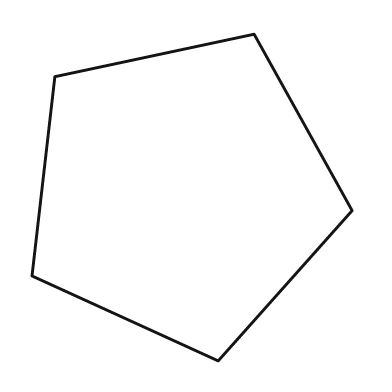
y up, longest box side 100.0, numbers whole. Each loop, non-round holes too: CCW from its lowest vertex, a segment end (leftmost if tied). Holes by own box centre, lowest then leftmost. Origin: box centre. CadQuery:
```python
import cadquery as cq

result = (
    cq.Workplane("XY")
    .moveTo(8.0, -50.0)
    .lineTo(49.0, -4.0)
    .lineTo(19.0, 50.0)
    .lineTo(-42.0, 37.0)
    .lineTo(-49.0, -24.0)
    .close()
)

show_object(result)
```